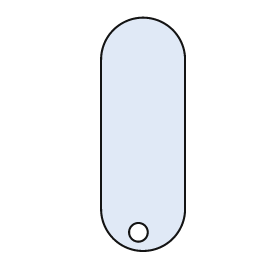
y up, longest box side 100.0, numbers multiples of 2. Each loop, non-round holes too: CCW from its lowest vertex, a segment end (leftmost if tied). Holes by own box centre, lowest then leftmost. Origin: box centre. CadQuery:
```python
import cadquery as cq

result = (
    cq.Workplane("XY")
    .moveTo(-18.0, -32.0)
    .threePointArc((0.0, -50.0), (18.0, -32.0))
    .lineTo(18.0, 32.0)
    .threePointArc((0.0, 50.0), (-18.0, 32.0))
    .close()
    .moveTo(-2.0, -42.0)
    .circle(4.0)
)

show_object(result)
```